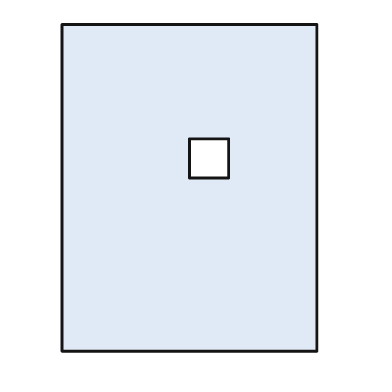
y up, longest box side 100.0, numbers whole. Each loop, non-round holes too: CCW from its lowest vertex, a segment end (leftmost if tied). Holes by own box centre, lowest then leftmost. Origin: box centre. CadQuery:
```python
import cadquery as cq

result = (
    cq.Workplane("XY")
    .moveTo(-39.0, -50.0)
    .lineTo(39.0, -50.0)
    .lineTo(39.0, 50.0)
    .lineTo(-39.0, 50.0)
    .close()
    .moveTo(0.0, 3.0)
    .lineTo(12.0, 3.0)
    .lineTo(12.0, 15.0)
    .lineTo(0.0, 15.0)
    .close()
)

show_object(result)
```